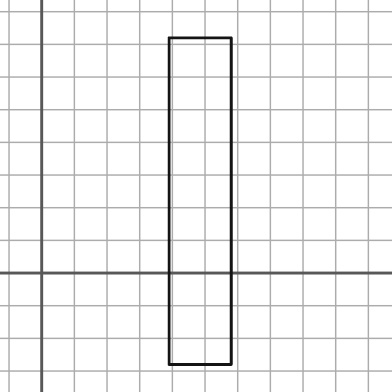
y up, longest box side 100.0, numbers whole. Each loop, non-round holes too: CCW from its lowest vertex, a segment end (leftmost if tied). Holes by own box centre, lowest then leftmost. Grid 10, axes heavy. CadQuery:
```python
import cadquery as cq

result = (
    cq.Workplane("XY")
    .moveTo(39.0, -28.0)
    .lineTo(58.0, -28.0)
    .lineTo(58.0, 72.0)
    .lineTo(39.0, 72.0)
    .close()
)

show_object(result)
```